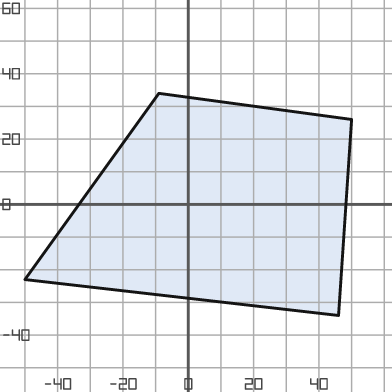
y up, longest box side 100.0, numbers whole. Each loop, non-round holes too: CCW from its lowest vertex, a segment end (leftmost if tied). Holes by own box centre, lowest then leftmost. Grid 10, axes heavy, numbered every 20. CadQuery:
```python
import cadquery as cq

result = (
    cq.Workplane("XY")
    .moveTo(46.0, -34.0)
    .lineTo(50.0, 26.0)
    .lineTo(-9.0, 34.0)
    .lineTo(-50.0, -23.0)
    .close()
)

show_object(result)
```